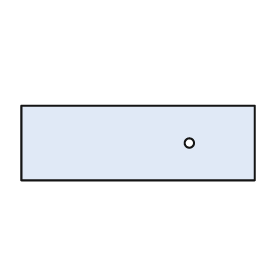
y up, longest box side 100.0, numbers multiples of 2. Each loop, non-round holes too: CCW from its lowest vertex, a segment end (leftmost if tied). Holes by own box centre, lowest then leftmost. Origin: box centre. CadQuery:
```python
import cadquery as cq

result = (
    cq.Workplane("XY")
    .moveTo(-50.0, -16.0)
    .lineTo(50.0, -16.0)
    .lineTo(50.0, 16.0)
    .lineTo(-50.0, 16.0)
    .close()
    .moveTo(22.0, 0.0)
    .circle(2.0)
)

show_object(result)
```